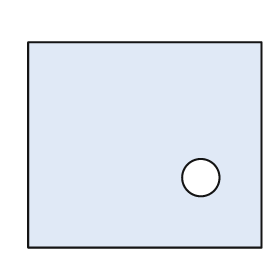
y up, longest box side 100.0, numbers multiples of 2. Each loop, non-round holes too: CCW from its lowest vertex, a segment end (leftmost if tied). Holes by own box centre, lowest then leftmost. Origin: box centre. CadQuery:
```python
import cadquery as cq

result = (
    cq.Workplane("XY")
    .moveTo(-50.0, -44.0)
    .lineTo(50.0, -44.0)
    .lineTo(50.0, 44.0)
    .lineTo(-50.0, 44.0)
    .close()
    .moveTo(24.0, -14.0)
    .circle(8.0)
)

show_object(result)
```